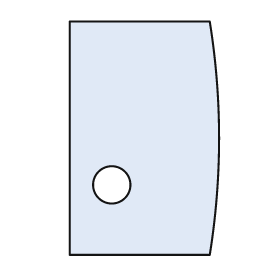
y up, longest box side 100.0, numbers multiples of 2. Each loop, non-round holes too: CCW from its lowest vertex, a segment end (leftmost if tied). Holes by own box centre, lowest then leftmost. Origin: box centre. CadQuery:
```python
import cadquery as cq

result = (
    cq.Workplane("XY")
    .moveTo(-32.0, -50.0)
    .lineTo(28.0, -50.0)
    .threePointArc((32.0, 0.0), (28.0, 50.0))
    .lineTo(-32.0, 50.0)
    .close()
    .moveTo(-14.0, -20.0)
    .circle(8.0)
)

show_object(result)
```